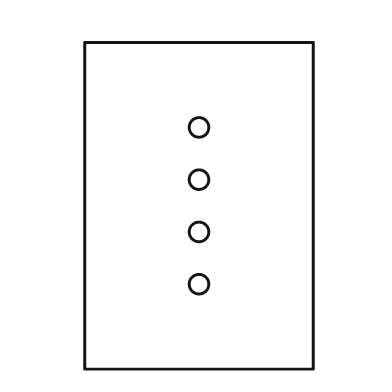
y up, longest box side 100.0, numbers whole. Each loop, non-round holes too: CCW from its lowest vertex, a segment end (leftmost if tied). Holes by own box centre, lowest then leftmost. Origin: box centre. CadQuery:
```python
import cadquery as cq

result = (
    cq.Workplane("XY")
    .moveTo(-35.0, -50.0)
    .lineTo(35.0, -50.0)
    .lineTo(35.0, 50.0)
    .lineTo(-35.0, 50.0)
    .close()
    .moveTo(0.0, -24.0)
    .circle(3.0)
    .moveTo(0.0, -8.0)
    .circle(3.0)
    .moveTo(0.0, 8.0)
    .circle(3.0)
    .moveTo(0.0, 24.0)
    .circle(3.0)
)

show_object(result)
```